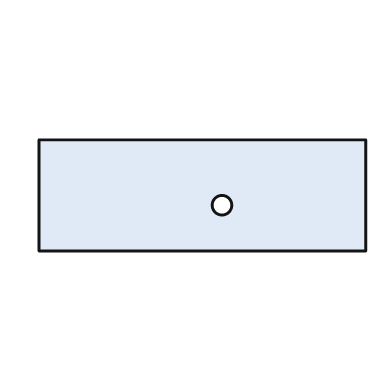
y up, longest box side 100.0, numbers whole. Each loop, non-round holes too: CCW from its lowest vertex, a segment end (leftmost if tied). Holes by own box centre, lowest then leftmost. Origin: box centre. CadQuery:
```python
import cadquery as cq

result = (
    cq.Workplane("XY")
    .moveTo(-50.0, -17.0)
    .lineTo(50.0, -17.0)
    .lineTo(50.0, 17.0)
    .lineTo(-50.0, 17.0)
    .close()
    .moveTo(6.0, -3.0)
    .circle(3.0)
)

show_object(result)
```